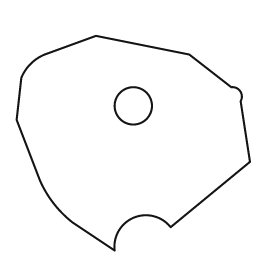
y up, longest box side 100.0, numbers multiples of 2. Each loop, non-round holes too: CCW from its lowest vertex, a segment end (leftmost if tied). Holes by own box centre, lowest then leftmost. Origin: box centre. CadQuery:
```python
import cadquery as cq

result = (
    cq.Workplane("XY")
    .moveTo(-8.0, -46.0)
    .threePointArc((0.0, -32.0), (16.0, -36.0))
    .lineTo(50.0, -8.0)
    .lineTo(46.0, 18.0)
    .threePointArc((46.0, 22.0), (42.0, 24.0))
    .lineTo(24.0, 38.0)
    .lineTo(-16.0, 46.0)
    .lineTo(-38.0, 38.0)
    .threePointArc((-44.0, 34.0), (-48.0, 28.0))
    .lineTo(-50.0, 10.0)
    .lineTo(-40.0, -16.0)
    .threePointArc((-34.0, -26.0), (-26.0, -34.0))
    .close()
    .moveTo(0.0, 16.0)
    .circle(8.0)
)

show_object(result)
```